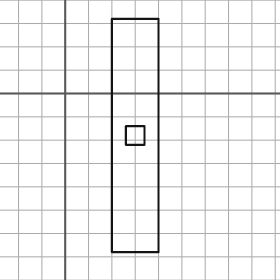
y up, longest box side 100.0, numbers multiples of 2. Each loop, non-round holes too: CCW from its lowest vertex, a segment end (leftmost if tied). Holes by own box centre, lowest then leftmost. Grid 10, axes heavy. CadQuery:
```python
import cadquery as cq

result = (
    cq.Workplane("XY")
    .moveTo(20.0, -68.0)
    .lineTo(40.0, -68.0)
    .lineTo(40.0, 32.0)
    .lineTo(20.0, 32.0)
    .close()
    .moveTo(26.0, -22.0)
    .lineTo(34.0, -22.0)
    .lineTo(34.0, -14.0)
    .lineTo(26.0, -14.0)
    .close()
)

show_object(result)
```